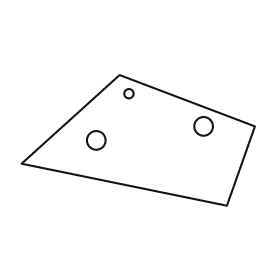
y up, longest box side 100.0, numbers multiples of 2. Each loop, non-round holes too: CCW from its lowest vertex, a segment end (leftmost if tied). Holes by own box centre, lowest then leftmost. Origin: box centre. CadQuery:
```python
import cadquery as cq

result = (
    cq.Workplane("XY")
    .moveTo(38.0, -28.0)
    .lineTo(50.0, 6.0)
    .lineTo(-8.0, 28.0)
    .lineTo(-50.0, -10.0)
    .close()
    .moveTo(-18.0, 0.0)
    .circle(4.0)
    .moveTo(28.0, 6.0)
    .circle(4.0)
    .moveTo(-4.0, 20.0)
    .circle(2.0)
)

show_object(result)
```